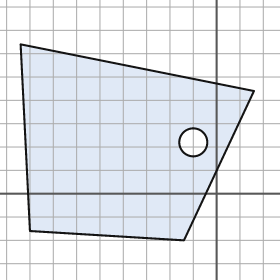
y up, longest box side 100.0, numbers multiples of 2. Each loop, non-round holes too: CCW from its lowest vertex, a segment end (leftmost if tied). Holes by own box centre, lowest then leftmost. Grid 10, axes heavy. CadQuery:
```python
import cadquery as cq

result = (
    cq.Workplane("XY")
    .moveTo(-14.0, -20.0)
    .lineTo(16.0, 44.0)
    .lineTo(-84.0, 64.0)
    .lineTo(-80.0, -16.0)
    .close()
    .moveTo(-10.0, 22.0)
    .circle(6.0)
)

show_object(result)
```